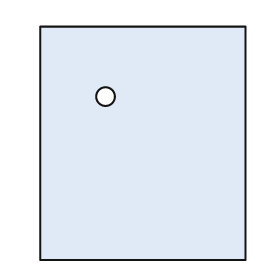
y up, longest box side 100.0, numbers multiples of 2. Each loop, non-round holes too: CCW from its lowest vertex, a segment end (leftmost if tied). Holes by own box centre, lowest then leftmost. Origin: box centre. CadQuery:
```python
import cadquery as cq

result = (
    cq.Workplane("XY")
    .moveTo(-44.0, -50.0)
    .lineTo(44.0, -50.0)
    .lineTo(44.0, 50.0)
    .lineTo(-44.0, 50.0)
    .close()
    .moveTo(-16.0, 20.0)
    .circle(4.0)
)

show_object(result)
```